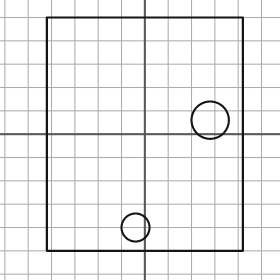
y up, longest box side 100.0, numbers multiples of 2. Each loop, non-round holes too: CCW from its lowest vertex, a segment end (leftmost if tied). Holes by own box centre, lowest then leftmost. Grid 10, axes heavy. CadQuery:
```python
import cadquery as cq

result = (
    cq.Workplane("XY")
    .moveTo(-42.0, -50.0)
    .lineTo(42.0, -50.0)
    .lineTo(42.0, 50.0)
    .lineTo(-42.0, 50.0)
    .close()
    .moveTo(-4.0, -40.0)
    .circle(6.0)
    .moveTo(28.0, 6.0)
    .circle(8.0)
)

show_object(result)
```